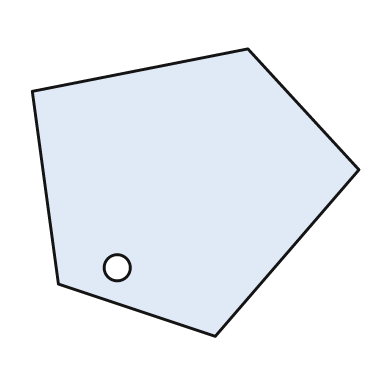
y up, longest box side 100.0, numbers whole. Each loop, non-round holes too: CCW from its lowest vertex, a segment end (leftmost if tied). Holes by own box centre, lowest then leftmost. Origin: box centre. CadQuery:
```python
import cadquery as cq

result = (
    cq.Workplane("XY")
    .moveTo(6.0, -44.0)
    .lineTo(50.0, 7.0)
    .lineTo(16.0, 44.0)
    .lineTo(-50.0, 31.0)
    .lineTo(-42.0, -28.0)
    .close()
    .moveTo(-24.0, -23.0)
    .circle(4.0)
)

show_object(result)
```